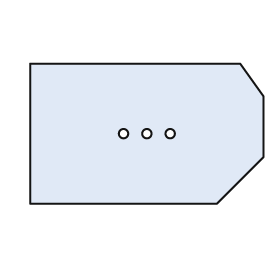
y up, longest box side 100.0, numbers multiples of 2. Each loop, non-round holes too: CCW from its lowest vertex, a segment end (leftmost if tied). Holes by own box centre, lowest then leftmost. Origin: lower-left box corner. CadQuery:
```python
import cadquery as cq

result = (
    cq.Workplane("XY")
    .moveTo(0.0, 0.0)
    .lineTo(80.0, 0.0)
    .lineTo(100.0, 20.0)
    .lineTo(100.0, 46.0)
    .lineTo(90.0, 60.0)
    .lineTo(0.0, 60.0)
    .close()
    .moveTo(40.0, 30.0)
    .circle(2.0)
    .moveTo(50.0, 30.0)
    .circle(2.0)
    .moveTo(60.0, 30.0)
    .circle(2.0)
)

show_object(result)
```